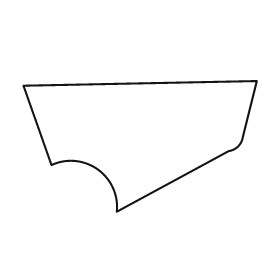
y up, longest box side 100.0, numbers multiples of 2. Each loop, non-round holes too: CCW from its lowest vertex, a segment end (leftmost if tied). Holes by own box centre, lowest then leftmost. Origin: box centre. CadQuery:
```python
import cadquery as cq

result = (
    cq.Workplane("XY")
    .moveTo(-10.0, -28.0)
    .lineTo(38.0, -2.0)
    .threePointArc((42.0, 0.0), (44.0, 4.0))
    .lineTo(50.0, 28.0)
    .lineTo(-50.0, 26.0)
    .lineTo(-38.0, -8.0)
    .threePointArc((-18.0, -10.0), (-10.0, -28.0))
    .close()
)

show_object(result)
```